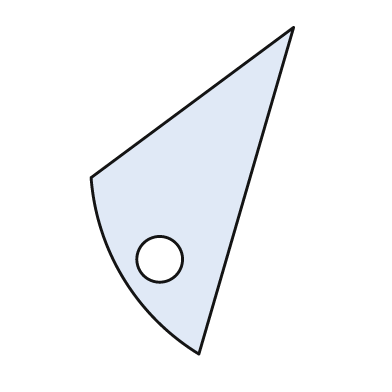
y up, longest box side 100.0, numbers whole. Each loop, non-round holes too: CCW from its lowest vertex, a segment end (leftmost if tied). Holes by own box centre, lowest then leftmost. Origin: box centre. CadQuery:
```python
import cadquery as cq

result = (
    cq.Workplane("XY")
    .moveTo(2.0, -50.0)
    .lineTo(31.0, 50.0)
    .lineTo(-31.0, 4.0)
    .threePointArc((-21.0, -27.0), (2.0, -50.0))
    .close()
    .moveTo(-10.0, -21.0)
    .circle(7.0)
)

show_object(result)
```